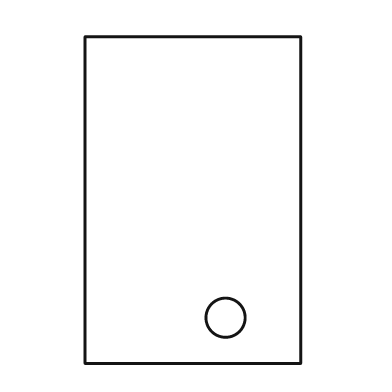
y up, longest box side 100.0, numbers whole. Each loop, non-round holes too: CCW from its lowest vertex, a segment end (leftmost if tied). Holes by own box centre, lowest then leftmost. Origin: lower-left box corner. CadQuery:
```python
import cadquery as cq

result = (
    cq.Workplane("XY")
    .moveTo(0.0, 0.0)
    .lineTo(66.0, 0.0)
    .lineTo(66.0, 100.0)
    .lineTo(0.0, 100.0)
    .close()
    .moveTo(43.0, 14.0)
    .circle(6.0)
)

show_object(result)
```